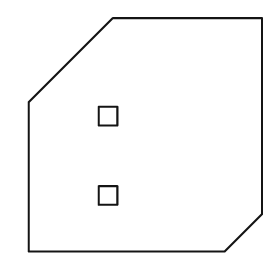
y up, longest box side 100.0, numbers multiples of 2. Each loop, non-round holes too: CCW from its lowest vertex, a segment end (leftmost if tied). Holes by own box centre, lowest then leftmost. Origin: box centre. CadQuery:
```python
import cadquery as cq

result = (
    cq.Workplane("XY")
    .moveTo(-50.0, -50.0)
    .lineTo(34.0, -50.0)
    .lineTo(50.0, -34.0)
    .lineTo(50.0, 50.0)
    .lineTo(-14.0, 50.0)
    .lineTo(-50.0, 14.0)
    .close()
    .moveTo(-20.0, -30.0)
    .lineTo(-12.0, -30.0)
    .lineTo(-12.0, -22.0)
    .lineTo(-20.0, -22.0)
    .close()
    .moveTo(-20.0, 4.0)
    .lineTo(-12.0, 4.0)
    .lineTo(-12.0, 12.0)
    .lineTo(-20.0, 12.0)
    .close()
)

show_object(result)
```